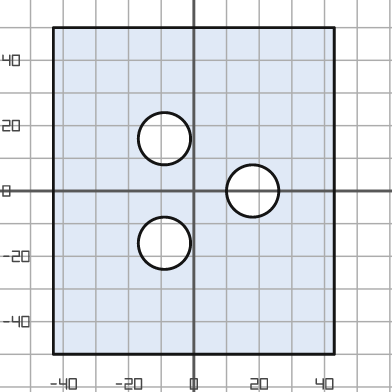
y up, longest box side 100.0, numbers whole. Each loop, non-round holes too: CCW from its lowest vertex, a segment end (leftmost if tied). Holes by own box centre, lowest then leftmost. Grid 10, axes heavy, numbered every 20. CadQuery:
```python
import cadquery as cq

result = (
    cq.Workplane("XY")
    .moveTo(-43.0, -50.0)
    .lineTo(43.0, -50.0)
    .lineTo(43.0, 50.0)
    .lineTo(-43.0, 50.0)
    .close()
    .moveTo(-9.0, -16.0)
    .circle(8.0)
    .moveTo(18.0, 0.0)
    .circle(8.0)
    .moveTo(-9.0, 16.0)
    .circle(8.0)
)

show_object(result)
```